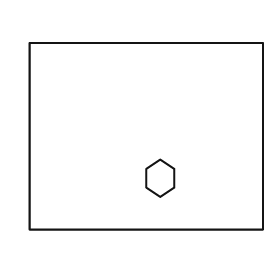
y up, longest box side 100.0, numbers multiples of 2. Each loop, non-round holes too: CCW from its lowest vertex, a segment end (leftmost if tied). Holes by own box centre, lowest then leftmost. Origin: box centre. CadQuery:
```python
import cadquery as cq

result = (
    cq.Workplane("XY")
    .moveTo(-50.0, -40.0)
    .lineTo(50.0, -40.0)
    .lineTo(50.0, 40.0)
    .lineTo(-50.0, 40.0)
    .close()
    .moveTo(6.0, -26.0)
    .lineTo(12.0, -22.0)
    .lineTo(12.0, -14.0)
    .lineTo(6.0, -10.0)
    .lineTo(0.0, -14.0)
    .lineTo(0.0, -22.0)
    .close()
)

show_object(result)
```